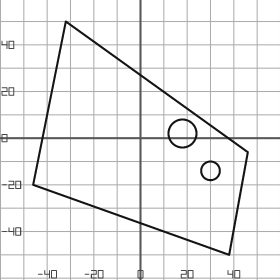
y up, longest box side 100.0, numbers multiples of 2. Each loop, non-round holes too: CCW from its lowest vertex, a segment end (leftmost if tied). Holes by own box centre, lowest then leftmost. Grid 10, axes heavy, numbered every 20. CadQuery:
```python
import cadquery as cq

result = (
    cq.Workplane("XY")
    .moveTo(38.0, -50.0)
    .lineTo(46.0, -6.0)
    .lineTo(-32.0, 50.0)
    .lineTo(-46.0, -20.0)
    .close()
    .moveTo(30.0, -14.0)
    .circle(4.0)
    .moveTo(18.0, 2.0)
    .circle(6.0)
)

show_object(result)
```